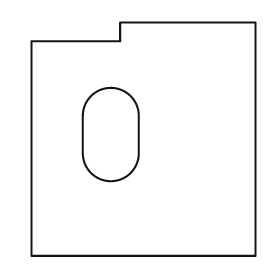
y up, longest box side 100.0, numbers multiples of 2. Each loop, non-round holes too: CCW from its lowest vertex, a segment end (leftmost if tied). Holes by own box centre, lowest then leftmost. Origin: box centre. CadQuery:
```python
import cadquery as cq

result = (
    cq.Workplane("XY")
    .moveTo(-48.0, -50.0)
    .lineTo(48.0, -50.0)
    .lineTo(48.0, 50.0)
    .lineTo(-10.0, 50.0)
    .lineTo(-10.0, 42.0)
    .lineTo(-48.0, 42.0)
    .close()
    .moveTo(-26.0, -6.0)
    .threePointArc((-14.0, -18.0), (-2.0, -6.0))
    .lineTo(-2.0, 10.0)
    .threePointArc((-14.0, 22.0), (-26.0, 10.0))
    .close()
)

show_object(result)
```